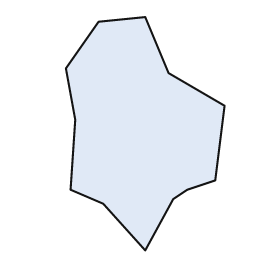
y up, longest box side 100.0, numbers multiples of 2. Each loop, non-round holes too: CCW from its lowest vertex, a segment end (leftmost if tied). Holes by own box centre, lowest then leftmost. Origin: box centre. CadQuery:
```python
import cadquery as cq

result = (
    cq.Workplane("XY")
    .moveTo(0.0, -50.0)
    .lineTo(12.0, -28.0)
    .lineTo(18.0, -24.0)
    .lineTo(30.0, -20.0)
    .lineTo(34.0, 12.0)
    .lineTo(10.0, 26.0)
    .lineTo(0.0, 50.0)
    .lineTo(-20.0, 48.0)
    .lineTo(-34.0, 28.0)
    .lineTo(-30.0, 6.0)
    .lineTo(-32.0, -24.0)
    .lineTo(-18.0, -30.0)
    .close()
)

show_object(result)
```